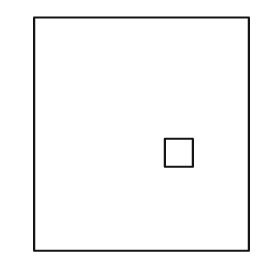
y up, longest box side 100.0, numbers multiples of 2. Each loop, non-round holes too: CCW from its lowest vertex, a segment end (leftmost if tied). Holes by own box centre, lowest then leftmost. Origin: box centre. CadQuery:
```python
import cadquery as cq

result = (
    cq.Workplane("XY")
    .moveTo(-46.0, -50.0)
    .lineTo(46.0, -50.0)
    .lineTo(46.0, 50.0)
    .lineTo(-46.0, 50.0)
    .close()
    .moveTo(10.0, -14.0)
    .lineTo(22.0, -14.0)
    .lineTo(22.0, -2.0)
    .lineTo(10.0, -2.0)
    .close()
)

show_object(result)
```